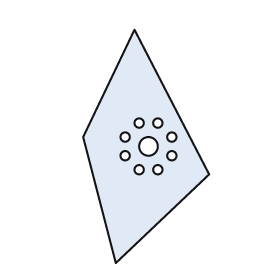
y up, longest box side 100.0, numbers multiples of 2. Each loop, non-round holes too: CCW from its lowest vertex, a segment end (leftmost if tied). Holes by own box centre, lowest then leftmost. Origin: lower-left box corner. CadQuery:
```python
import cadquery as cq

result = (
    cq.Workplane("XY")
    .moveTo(14.0, 0.0)
    .lineTo(54.0, 38.0)
    .lineTo(22.0, 100.0)
    .lineTo(0.0, 54.0)
    .close()
    .moveTo(24.0, 40.0)
    .circle(2.0)
    .moveTo(32.0, 40.0)
    .circle(2.0)
    .moveTo(18.0, 46.0)
    .circle(2.0)
    .moveTo(38.0, 46.0)
    .circle(2.0)
    .moveTo(28.0, 50.0)
    .circle(4.0)
    .moveTo(18.0, 54.0)
    .circle(2.0)
    .moveTo(38.0, 54.0)
    .circle(2.0)
    .moveTo(24.0, 60.0)
    .circle(2.0)
    .moveTo(32.0, 60.0)
    .circle(2.0)
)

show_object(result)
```